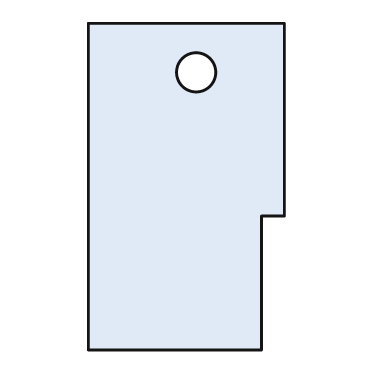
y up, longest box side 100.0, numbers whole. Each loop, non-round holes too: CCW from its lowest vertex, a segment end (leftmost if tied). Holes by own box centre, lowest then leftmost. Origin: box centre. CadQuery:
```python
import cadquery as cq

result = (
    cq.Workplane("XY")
    .moveTo(-30.0, -50.0)
    .lineTo(23.0, -50.0)
    .lineTo(23.0, -9.0)
    .lineTo(30.0, -9.0)
    .lineTo(30.0, 50.0)
    .lineTo(-30.0, 50.0)
    .close()
    .moveTo(3.0, 35.0)
    .circle(6.0)
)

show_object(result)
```